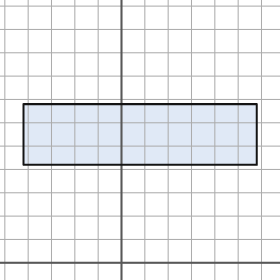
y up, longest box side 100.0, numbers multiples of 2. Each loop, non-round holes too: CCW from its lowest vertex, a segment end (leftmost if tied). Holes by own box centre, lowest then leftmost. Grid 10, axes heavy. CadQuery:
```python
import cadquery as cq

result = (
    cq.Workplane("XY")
    .moveTo(-42.0, 42.0)
    .lineTo(58.0, 42.0)
    .lineTo(58.0, 68.0)
    .lineTo(-42.0, 68.0)
    .close()
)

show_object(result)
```